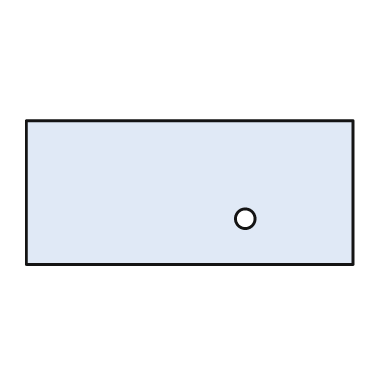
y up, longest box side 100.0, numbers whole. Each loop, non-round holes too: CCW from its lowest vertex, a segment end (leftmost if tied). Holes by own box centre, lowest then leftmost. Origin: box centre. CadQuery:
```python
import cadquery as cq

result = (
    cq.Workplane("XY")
    .moveTo(-50.0, -22.0)
    .lineTo(50.0, -22.0)
    .lineTo(50.0, 22.0)
    .lineTo(-50.0, 22.0)
    .close()
    .moveTo(17.0, -8.0)
    .circle(3.0)
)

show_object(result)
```